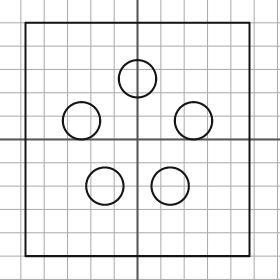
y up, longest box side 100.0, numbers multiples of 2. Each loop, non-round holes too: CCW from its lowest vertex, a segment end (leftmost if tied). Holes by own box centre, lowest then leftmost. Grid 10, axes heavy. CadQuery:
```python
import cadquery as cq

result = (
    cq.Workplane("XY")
    .moveTo(-48.0, -50.0)
    .lineTo(48.0, -50.0)
    .lineTo(48.0, 50.0)
    .lineTo(-48.0, 50.0)
    .close()
    .moveTo(-14.0, -20.0)
    .circle(8.0)
    .moveTo(14.0, -20.0)
    .circle(8.0)
    .moveTo(-24.0, 8.0)
    .circle(8.0)
    .moveTo(24.0, 8.0)
    .circle(8.0)
    .moveTo(0.0, 26.0)
    .circle(8.0)
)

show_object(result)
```